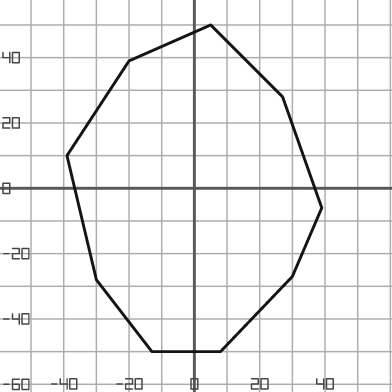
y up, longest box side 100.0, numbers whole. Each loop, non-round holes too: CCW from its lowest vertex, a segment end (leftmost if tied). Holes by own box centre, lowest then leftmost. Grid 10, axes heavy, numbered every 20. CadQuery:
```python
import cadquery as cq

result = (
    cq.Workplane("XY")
    .moveTo(-13.0, -50.0)
    .lineTo(8.0, -50.0)
    .lineTo(30.0, -27.0)
    .lineTo(39.0, -6.0)
    .lineTo(27.0, 28.0)
    .lineTo(5.0, 50.0)
    .lineTo(-20.0, 39.0)
    .lineTo(-39.0, 10.0)
    .lineTo(-30.0, -28.0)
    .close()
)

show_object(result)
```